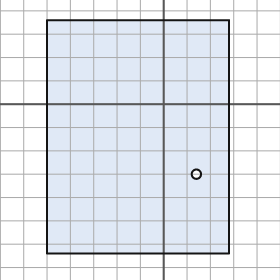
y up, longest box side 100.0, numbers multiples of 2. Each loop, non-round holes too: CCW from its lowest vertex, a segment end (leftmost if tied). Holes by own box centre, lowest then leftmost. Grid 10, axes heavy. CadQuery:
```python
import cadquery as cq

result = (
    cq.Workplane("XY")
    .moveTo(-50.0, -64.0)
    .lineTo(28.0, -64.0)
    .lineTo(28.0, 36.0)
    .lineTo(-50.0, 36.0)
    .close()
    .moveTo(14.0, -30.0)
    .circle(2.0)
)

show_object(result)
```